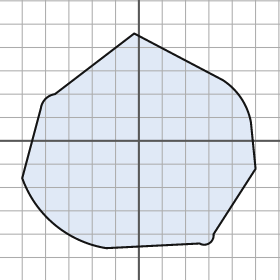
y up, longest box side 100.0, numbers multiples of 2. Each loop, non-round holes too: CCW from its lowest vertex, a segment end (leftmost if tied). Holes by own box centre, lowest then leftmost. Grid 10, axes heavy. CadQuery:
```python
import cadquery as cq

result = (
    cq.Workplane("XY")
    .moveTo(-14.0, -46.0)
    .lineTo(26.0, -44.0)
    .threePointArc((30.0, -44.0), (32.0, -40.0))
    .lineTo(50.0, -12.0)
    .lineTo(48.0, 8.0)
    .threePointArc((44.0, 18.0), (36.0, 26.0))
    .lineTo(-2.0, 46.0)
    .lineTo(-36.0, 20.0)
    .threePointArc((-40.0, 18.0), (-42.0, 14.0))
    .lineTo(-50.0, -16.0)
    .threePointArc((-36.0, -36.0), (-14.0, -46.0))
    .close()
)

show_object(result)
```